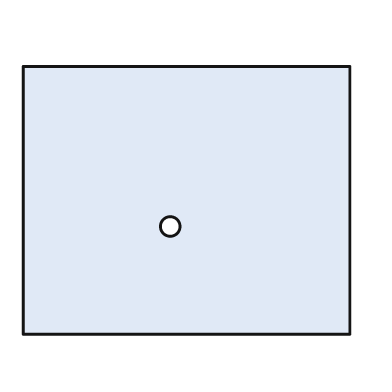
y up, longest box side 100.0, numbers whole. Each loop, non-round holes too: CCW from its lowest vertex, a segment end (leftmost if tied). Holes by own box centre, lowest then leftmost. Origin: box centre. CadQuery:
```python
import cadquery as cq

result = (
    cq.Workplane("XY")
    .moveTo(-50.0, -41.0)
    .lineTo(50.0, -41.0)
    .lineTo(50.0, 41.0)
    .lineTo(-50.0, 41.0)
    .close()
    .moveTo(-5.0, -8.0)
    .circle(3.0)
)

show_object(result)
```